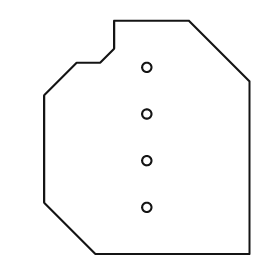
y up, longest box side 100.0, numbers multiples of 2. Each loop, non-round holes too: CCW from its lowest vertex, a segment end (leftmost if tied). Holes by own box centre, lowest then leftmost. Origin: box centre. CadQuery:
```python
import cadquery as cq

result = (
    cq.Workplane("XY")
    .moveTo(-22.0, -50.0)
    .lineTo(44.0, -50.0)
    .lineTo(44.0, 24.0)
    .lineTo(18.0, 50.0)
    .lineTo(-14.0, 50.0)
    .lineTo(-14.0, 38.0)
    .lineTo(-20.0, 32.0)
    .lineTo(-30.0, 32.0)
    .lineTo(-44.0, 18.0)
    .lineTo(-44.0, -28.0)
    .close()
    .moveTo(0.0, -30.0)
    .circle(2.0)
    .moveTo(0.0, -10.0)
    .circle(2.0)
    .moveTo(0.0, 10.0)
    .circle(2.0)
    .moveTo(0.0, 30.0)
    .circle(2.0)
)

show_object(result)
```